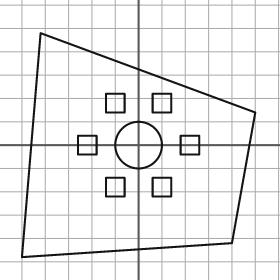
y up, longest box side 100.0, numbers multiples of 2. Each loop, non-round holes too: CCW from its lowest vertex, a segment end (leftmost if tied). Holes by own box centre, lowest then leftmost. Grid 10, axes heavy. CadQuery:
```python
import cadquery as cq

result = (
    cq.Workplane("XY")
    .moveTo(-50.0, -48.0)
    .lineTo(40.0, -42.0)
    .lineTo(50.0, 14.0)
    .lineTo(-42.0, 48.0)
    .close()
    .moveTo(-14.0, -22.0)
    .lineTo(-6.0, -22.0)
    .lineTo(-6.0, -14.0)
    .lineTo(-14.0, -14.0)
    .close()
    .moveTo(6.0, -22.0)
    .lineTo(14.0, -22.0)
    .lineTo(14.0, -14.0)
    .lineTo(6.0, -14.0)
    .close()
    .moveTo(-26.0, -4.0)
    .lineTo(-18.0, -4.0)
    .lineTo(-18.0, 4.0)
    .lineTo(-26.0, 4.0)
    .close()
    .moveTo(0.0, 0.0)
    .circle(10.0)
    .moveTo(18.0, -4.0)
    .lineTo(26.0, -4.0)
    .lineTo(26.0, 4.0)
    .lineTo(18.0, 4.0)
    .close()
    .moveTo(-14.0, 14.0)
    .lineTo(-6.0, 14.0)
    .lineTo(-6.0, 22.0)
    .lineTo(-14.0, 22.0)
    .close()
    .moveTo(6.0, 14.0)
    .lineTo(14.0, 14.0)
    .lineTo(14.0, 22.0)
    .lineTo(6.0, 22.0)
    .close()
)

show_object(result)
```